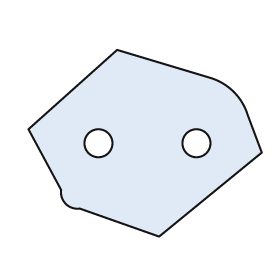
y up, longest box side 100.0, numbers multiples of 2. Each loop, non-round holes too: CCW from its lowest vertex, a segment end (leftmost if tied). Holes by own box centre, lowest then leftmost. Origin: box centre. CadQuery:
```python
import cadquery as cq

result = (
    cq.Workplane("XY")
    .moveTo(6.0, -40.0)
    .lineTo(50.0, -4.0)
    .lineTo(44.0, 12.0)
    .threePointArc((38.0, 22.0), (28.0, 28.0))
    .lineTo(-12.0, 40.0)
    .lineTo(-50.0, 6.0)
    .lineTo(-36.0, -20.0)
    .threePointArc((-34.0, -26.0), (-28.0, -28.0))
    .close()
    .moveTo(-20.0, 0.0)
    .circle(6.0)
    .moveTo(22.0, 0.0)
    .circle(6.0)
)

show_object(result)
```